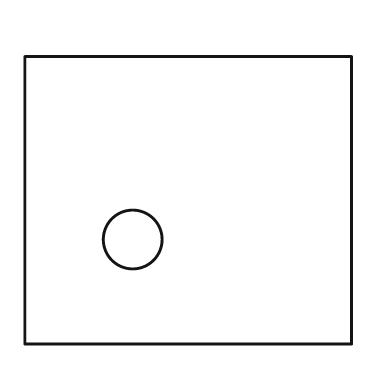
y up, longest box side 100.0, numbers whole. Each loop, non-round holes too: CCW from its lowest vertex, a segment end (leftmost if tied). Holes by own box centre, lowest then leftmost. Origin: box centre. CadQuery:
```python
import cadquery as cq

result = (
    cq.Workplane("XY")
    .moveTo(-50.0, -44.0)
    .lineTo(50.0, -44.0)
    .lineTo(50.0, 44.0)
    .lineTo(-50.0, 44.0)
    .close()
    .moveTo(-17.0, -12.0)
    .circle(9.0)
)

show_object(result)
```